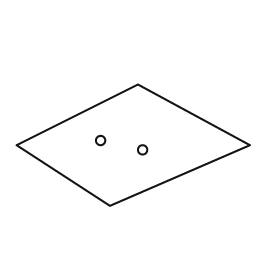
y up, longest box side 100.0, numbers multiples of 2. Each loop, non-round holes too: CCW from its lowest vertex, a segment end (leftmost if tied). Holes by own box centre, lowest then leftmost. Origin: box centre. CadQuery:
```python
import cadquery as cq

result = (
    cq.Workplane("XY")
    .moveTo(-10.0, -26.0)
    .lineTo(50.0, 0.0)
    .lineTo(2.0, 26.0)
    .lineTo(-50.0, 0.0)
    .close()
    .moveTo(4.0, -2.0)
    .circle(2.0)
    .moveTo(-14.0, 2.0)
    .circle(2.0)
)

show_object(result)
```